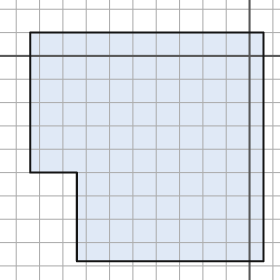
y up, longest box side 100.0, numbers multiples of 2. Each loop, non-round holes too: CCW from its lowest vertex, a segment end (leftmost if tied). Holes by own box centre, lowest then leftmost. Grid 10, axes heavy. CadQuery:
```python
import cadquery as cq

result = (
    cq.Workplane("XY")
    .moveTo(-74.0, -88.0)
    .lineTo(6.0, -88.0)
    .lineTo(6.0, 10.0)
    .lineTo(-94.0, 10.0)
    .lineTo(-94.0, -50.0)
    .lineTo(-74.0, -50.0)
    .close()
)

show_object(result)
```